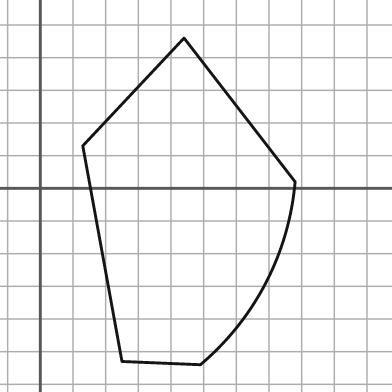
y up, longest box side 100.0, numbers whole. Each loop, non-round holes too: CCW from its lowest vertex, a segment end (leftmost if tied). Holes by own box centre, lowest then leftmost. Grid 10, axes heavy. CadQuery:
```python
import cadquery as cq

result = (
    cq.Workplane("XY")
    .moveTo(49.0, -54.0)
    .threePointArc((69.0, -29.0), (78.0, 2.0))
    .lineTo(44.0, 46.0)
    .lineTo(13.0, 13.0)
    .lineTo(25.0, -53.0)
    .close()
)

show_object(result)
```